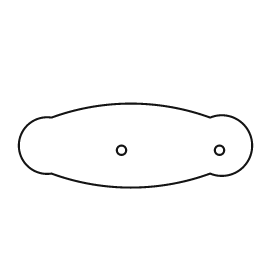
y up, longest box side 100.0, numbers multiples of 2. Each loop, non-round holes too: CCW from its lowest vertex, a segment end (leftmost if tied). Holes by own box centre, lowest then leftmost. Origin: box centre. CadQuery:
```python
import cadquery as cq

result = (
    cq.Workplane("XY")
    .moveTo(-36.0, -12.0)
    .threePointArc((-2.0, -18.0), (32.0, -12.0))
    .threePointArc((50.0, 0.0), (32.0, 12.0))
    .threePointArc((-2.0, 18.0), (-36.0, 12.0))
    .threePointArc((-50.0, 0.0), (-36.0, -12.0))
    .close()
    .moveTo(-6.0, -2.0)
    .circle(2.0)
    .moveTo(36.0, -2.0)
    .circle(2.0)
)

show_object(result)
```